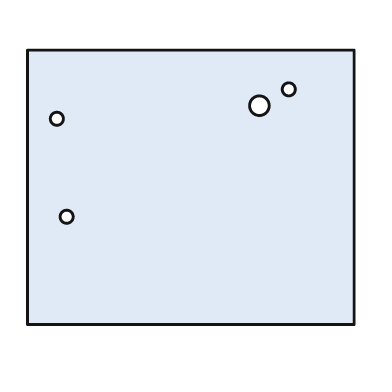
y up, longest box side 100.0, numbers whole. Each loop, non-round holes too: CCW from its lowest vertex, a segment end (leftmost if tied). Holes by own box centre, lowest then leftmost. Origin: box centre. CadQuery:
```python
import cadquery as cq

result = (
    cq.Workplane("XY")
    .moveTo(-50.0, -42.0)
    .lineTo(50.0, -42.0)
    .lineTo(50.0, 42.0)
    .lineTo(-50.0, 42.0)
    .close()
    .moveTo(-38.0, -9.0)
    .circle(2.0)
    .moveTo(-41.0, 21.0)
    .circle(2.0)
    .moveTo(21.0, 25.0)
    .circle(3.0)
    .moveTo(30.0, 30.0)
    .circle(2.0)
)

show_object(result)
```